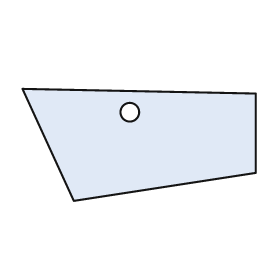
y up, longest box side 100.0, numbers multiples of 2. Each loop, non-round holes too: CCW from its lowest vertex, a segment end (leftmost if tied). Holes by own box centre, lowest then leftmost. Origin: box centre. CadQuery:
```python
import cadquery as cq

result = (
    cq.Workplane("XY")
    .moveTo(-28.0, -24.0)
    .lineTo(50.0, -12.0)
    .lineTo(50.0, 22.0)
    .lineTo(-50.0, 24.0)
    .close()
    .moveTo(-4.0, 14.0)
    .circle(4.0)
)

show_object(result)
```